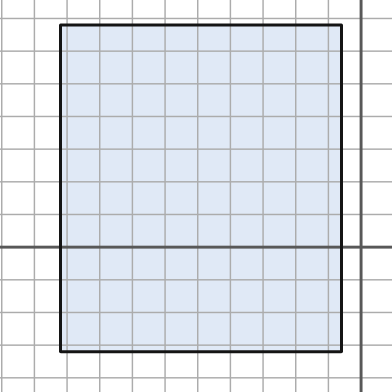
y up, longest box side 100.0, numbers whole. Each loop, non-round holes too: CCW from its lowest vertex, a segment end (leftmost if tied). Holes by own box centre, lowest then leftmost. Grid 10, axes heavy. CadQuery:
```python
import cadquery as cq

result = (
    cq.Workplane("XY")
    .moveTo(-92.0, -32.0)
    .lineTo(-6.0, -32.0)
    .lineTo(-6.0, 68.0)
    .lineTo(-92.0, 68.0)
    .close()
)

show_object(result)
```